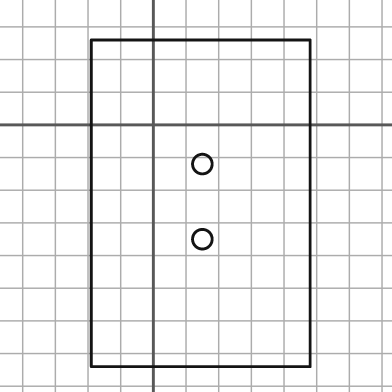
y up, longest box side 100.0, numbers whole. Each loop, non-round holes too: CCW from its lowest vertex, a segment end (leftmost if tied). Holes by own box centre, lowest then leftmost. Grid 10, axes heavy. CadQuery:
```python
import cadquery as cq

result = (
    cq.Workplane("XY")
    .moveTo(-19.0, -74.0)
    .lineTo(48.0, -74.0)
    .lineTo(48.0, 26.0)
    .lineTo(-19.0, 26.0)
    .close()
    .moveTo(15.0, -35.0)
    .circle(3.0)
    .moveTo(15.0, -12.0)
    .circle(3.0)
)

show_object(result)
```